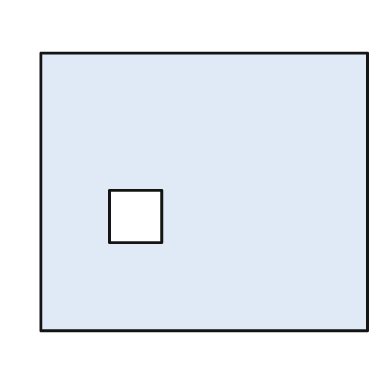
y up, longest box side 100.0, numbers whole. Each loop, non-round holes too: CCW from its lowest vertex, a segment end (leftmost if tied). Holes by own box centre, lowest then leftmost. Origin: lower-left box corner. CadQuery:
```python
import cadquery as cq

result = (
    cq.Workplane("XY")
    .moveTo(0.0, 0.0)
    .lineTo(100.0, 0.0)
    .lineTo(100.0, 85.0)
    .lineTo(0.0, 85.0)
    .close()
    .moveTo(21.0, 27.0)
    .lineTo(37.0, 27.0)
    .lineTo(37.0, 43.0)
    .lineTo(21.0, 43.0)
    .close()
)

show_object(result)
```